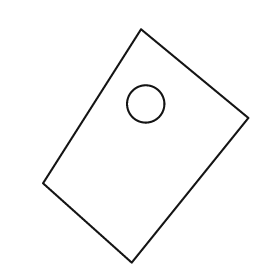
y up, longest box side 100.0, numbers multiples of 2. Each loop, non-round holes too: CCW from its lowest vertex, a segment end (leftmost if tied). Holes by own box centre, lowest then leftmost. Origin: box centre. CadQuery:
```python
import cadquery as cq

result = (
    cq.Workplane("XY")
    .moveTo(-6.0, -50.0)
    .lineTo(44.0, 12.0)
    .lineTo(-2.0, 50.0)
    .lineTo(-44.0, -16.0)
    .close()
    .moveTo(0.0, 18.0)
    .circle(8.0)
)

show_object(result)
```